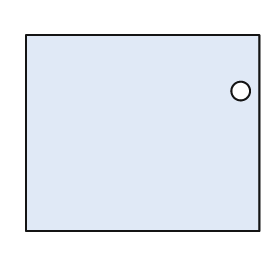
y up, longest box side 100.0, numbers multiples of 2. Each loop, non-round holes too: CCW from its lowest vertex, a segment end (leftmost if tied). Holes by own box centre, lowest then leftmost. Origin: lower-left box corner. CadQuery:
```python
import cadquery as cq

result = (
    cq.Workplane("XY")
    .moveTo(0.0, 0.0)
    .lineTo(100.0, 0.0)
    .lineTo(100.0, 84.0)
    .lineTo(0.0, 84.0)
    .close()
    .moveTo(92.0, 60.0)
    .circle(4.0)
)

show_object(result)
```